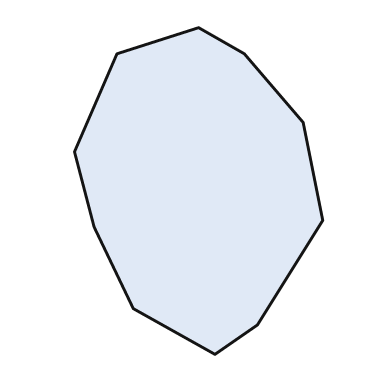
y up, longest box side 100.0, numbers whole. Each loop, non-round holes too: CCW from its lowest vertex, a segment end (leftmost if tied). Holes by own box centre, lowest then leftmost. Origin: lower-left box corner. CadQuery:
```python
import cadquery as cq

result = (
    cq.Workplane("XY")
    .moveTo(43.0, 0.0)
    .lineTo(56.0, 9.0)
    .lineTo(76.0, 41.0)
    .lineTo(70.0, 71.0)
    .lineTo(52.0, 92.0)
    .lineTo(38.0, 100.0)
    .lineTo(13.0, 92.0)
    .lineTo(0.0, 62.0)
    .lineTo(6.0, 39.0)
    .lineTo(18.0, 14.0)
    .close()
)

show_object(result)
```